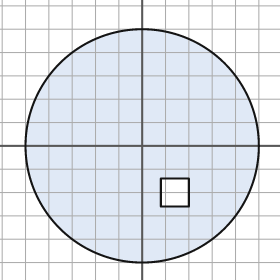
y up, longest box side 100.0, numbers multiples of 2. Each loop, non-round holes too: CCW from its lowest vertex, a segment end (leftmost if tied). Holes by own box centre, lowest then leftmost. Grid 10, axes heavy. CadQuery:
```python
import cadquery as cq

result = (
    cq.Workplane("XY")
    .moveTo(0.0, 0.0)
    .circle(50.0)
    .moveTo(8.0, -26.0)
    .lineTo(20.0, -26.0)
    .lineTo(20.0, -14.0)
    .lineTo(8.0, -14.0)
    .close()
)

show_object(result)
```